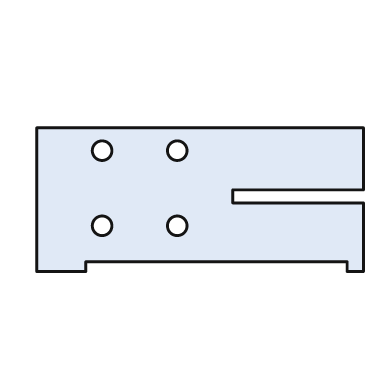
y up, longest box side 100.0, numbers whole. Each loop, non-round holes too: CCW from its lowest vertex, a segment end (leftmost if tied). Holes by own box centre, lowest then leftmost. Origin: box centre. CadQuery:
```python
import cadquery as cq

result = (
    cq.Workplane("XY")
    .moveTo(-50.0, -22.0)
    .lineTo(-35.0, -22.0)
    .lineTo(-35.0, -19.0)
    .lineTo(45.0, -19.0)
    .lineTo(45.0, -22.0)
    .lineTo(50.0, -22.0)
    .lineTo(50.0, -1.0)
    .lineTo(10.0, -1.0)
    .lineTo(10.0, 3.0)
    .lineTo(50.0, 3.0)
    .lineTo(50.0, 22.0)
    .lineTo(-50.0, 22.0)
    .close()
    .moveTo(-30.0, -8.0)
    .circle(3.0)
    .moveTo(-7.0, -8.0)
    .circle(3.0)
    .moveTo(-30.0, 15.0)
    .circle(3.0)
    .moveTo(-7.0, 15.0)
    .circle(3.0)
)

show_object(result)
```